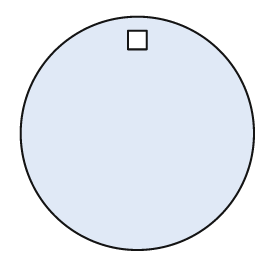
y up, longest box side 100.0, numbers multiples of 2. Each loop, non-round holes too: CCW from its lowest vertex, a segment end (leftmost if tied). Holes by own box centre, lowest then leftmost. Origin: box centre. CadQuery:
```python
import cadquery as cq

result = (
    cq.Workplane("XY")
    .moveTo(0.0, 0.0)
    .circle(50.0)
    .moveTo(-4.0, 36.0)
    .lineTo(4.0, 36.0)
    .lineTo(4.0, 44.0)
    .lineTo(-4.0, 44.0)
    .close()
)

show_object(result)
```